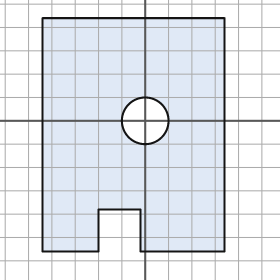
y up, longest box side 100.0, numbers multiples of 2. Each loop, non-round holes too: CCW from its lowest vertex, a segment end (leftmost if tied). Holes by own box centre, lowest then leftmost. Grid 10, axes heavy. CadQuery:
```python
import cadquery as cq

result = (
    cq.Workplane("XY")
    .moveTo(-44.0, -56.0)
    .lineTo(-20.0, -56.0)
    .lineTo(-20.0, -38.0)
    .lineTo(-2.0, -38.0)
    .lineTo(-2.0, -56.0)
    .lineTo(34.0, -56.0)
    .lineTo(34.0, 44.0)
    .lineTo(-44.0, 44.0)
    .close()
    .moveTo(0.0, 0.0)
    .circle(10.0)
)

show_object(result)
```